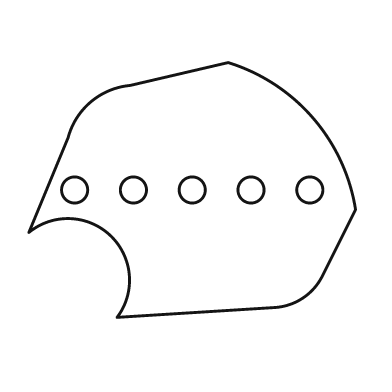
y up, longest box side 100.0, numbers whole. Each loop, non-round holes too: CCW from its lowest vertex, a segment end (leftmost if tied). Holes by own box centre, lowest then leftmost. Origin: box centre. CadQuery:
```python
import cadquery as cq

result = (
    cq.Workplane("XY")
    .moveTo(-23.0, -39.0)
    .lineTo(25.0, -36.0)
    .threePointArc((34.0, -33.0), (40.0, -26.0))
    .lineTo(50.0, -6.0)
    .threePointArc((37.0, 22.0), (11.0, 39.0))
    .lineTo(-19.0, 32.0)
    .threePointArc((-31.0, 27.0), (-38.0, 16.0))
    .lineTo(-50.0, -13.0)
    .threePointArc((-25.0, -14.0), (-23.0, -39.0))
    .close()
    .moveTo(-36.0, 0.0)
    .circle(4.0)
    .moveTo(-18.0, 0.0)
    .circle(4.0)
    .moveTo(0.0, 0.0)
    .circle(4.0)
    .moveTo(18.0, 0.0)
    .circle(4.0)
    .moveTo(36.0, 0.0)
    .circle(4.0)
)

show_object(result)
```